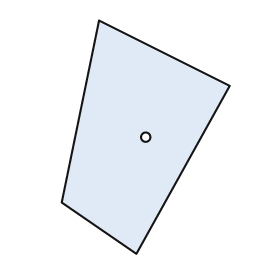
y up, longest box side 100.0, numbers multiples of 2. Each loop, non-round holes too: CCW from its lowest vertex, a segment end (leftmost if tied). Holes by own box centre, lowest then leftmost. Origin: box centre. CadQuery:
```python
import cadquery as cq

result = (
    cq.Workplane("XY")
    .moveTo(-4.0, -50.0)
    .lineTo(36.0, 22.0)
    .lineTo(-20.0, 50.0)
    .lineTo(-36.0, -28.0)
    .close()
    .moveTo(0.0, 0.0)
    .circle(2.0)
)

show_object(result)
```